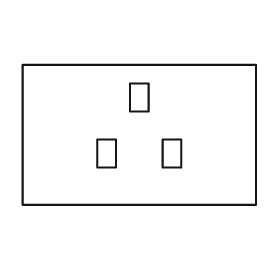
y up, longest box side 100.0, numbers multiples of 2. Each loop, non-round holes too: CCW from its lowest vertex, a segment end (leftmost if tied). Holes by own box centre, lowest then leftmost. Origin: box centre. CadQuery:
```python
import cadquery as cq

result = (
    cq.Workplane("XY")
    .moveTo(-50.0, -30.0)
    .lineTo(50.0, -30.0)
    .lineTo(50.0, 30.0)
    .lineTo(-50.0, 30.0)
    .close()
    .moveTo(-18.0, -14.0)
    .lineTo(-10.0, -14.0)
    .lineTo(-10.0, -2.0)
    .lineTo(-18.0, -2.0)
    .close()
    .moveTo(10.0, -14.0)
    .lineTo(18.0, -14.0)
    .lineTo(18.0, -2.0)
    .lineTo(10.0, -2.0)
    .close()
    .moveTo(-4.0, 10.0)
    .lineTo(4.0, 10.0)
    .lineTo(4.0, 22.0)
    .lineTo(-4.0, 22.0)
    .close()
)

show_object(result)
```